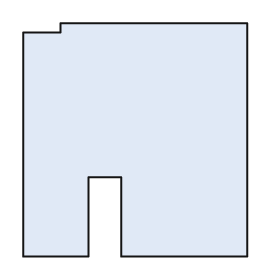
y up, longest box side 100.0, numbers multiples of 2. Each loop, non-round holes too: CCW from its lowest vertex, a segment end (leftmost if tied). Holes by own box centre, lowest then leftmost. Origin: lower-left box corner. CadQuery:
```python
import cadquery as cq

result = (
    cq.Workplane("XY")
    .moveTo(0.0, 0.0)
    .lineTo(28.0, 0.0)
    .lineTo(28.0, 34.0)
    .lineTo(42.0, 34.0)
    .lineTo(42.0, 0.0)
    .lineTo(96.0, 0.0)
    .lineTo(96.0, 100.0)
    .lineTo(16.0, 100.0)
    .lineTo(16.0, 96.0)
    .lineTo(0.0, 96.0)
    .close()
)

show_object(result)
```